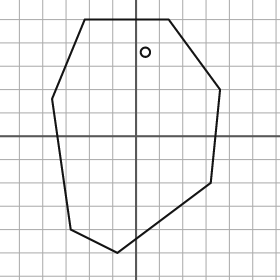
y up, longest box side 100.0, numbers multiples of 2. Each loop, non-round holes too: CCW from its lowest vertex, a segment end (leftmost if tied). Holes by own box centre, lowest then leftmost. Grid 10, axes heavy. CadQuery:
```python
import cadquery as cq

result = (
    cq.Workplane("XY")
    .moveTo(-8.0, -50.0)
    .lineTo(32.0, -20.0)
    .lineTo(36.0, 20.0)
    .lineTo(14.0, 50.0)
    .lineTo(-22.0, 50.0)
    .lineTo(-36.0, 16.0)
    .lineTo(-28.0, -40.0)
    .close()
    .moveTo(4.0, 36.0)
    .circle(2.0)
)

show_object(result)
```